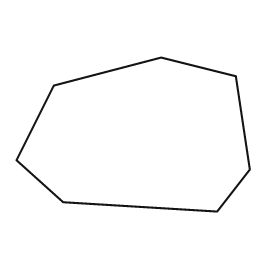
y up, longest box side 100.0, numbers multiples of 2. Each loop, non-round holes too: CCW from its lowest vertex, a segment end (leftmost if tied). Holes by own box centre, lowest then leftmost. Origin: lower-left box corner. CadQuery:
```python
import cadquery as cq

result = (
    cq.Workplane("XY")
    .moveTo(86.0, 0.0)
    .lineTo(100.0, 18.0)
    .lineTo(94.0, 58.0)
    .lineTo(62.0, 66.0)
    .lineTo(16.0, 54.0)
    .lineTo(0.0, 22.0)
    .lineTo(20.0, 4.0)
    .close()
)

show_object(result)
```